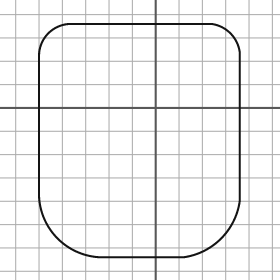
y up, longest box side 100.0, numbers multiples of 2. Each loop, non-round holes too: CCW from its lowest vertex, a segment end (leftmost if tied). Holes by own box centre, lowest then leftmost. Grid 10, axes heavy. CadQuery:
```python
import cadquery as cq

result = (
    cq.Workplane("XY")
    .moveTo(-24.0, -64.0)
    .lineTo(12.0, -64.0)
    .threePointArc((28.0, -56.0), (36.0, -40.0))
    .lineTo(36.0, 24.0)
    .threePointArc((32.0, 32.0), (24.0, 36.0))
    .lineTo(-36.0, 36.0)
    .threePointArc((-46.0, 32.0), (-50.0, 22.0))
    .lineTo(-50.0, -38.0)
    .threePointArc((-42.0, -56.0), (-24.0, -64.0))
    .close()
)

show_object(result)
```